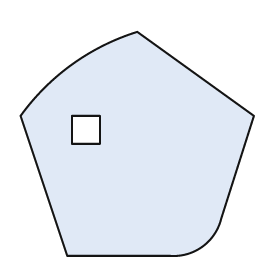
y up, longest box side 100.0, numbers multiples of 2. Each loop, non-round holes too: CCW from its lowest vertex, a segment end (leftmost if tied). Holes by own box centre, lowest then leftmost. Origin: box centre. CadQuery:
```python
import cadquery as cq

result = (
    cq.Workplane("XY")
    .moveTo(-30.0, -48.0)
    .lineTo(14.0, -48.0)
    .threePointArc((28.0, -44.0), (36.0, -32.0))
    .lineTo(50.0, 12.0)
    .lineTo(0.0, 48.0)
    .threePointArc((-28.0, 34.0), (-50.0, 12.0))
    .close()
    .moveTo(-28.0, 0.0)
    .lineTo(-16.0, 0.0)
    .lineTo(-16.0, 12.0)
    .lineTo(-28.0, 12.0)
    .close()
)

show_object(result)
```